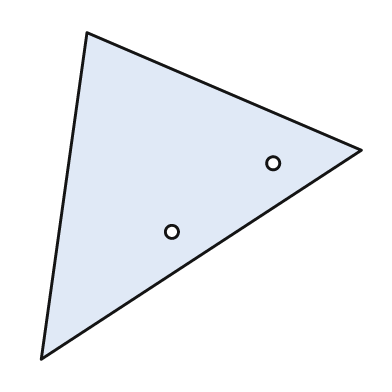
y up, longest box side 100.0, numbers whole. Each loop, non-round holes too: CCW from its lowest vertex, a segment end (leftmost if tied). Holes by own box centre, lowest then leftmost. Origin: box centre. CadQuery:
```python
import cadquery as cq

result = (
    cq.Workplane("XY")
    .moveTo(-49.0, -50.0)
    .lineTo(49.0, 14.0)
    .lineTo(-35.0, 50.0)
    .close()
    .moveTo(-9.0, -11.0)
    .circle(2.0)
    .moveTo(22.0, 10.0)
    .circle(2.0)
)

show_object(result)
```